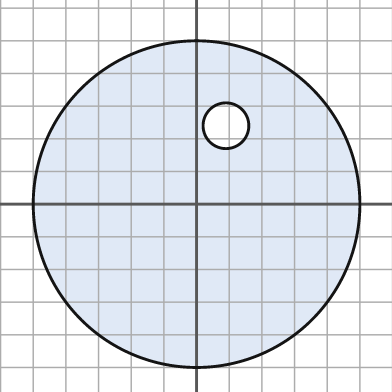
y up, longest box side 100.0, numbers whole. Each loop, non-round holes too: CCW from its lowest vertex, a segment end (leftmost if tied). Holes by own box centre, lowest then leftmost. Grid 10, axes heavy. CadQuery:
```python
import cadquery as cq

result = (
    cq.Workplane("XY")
    .moveTo(0.0, 0.0)
    .circle(50.0)
    .moveTo(9.0, 24.0)
    .circle(7.0)
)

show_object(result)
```